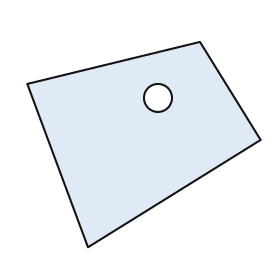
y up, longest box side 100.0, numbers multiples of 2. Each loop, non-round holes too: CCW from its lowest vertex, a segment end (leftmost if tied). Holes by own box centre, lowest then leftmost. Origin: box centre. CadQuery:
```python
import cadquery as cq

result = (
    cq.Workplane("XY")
    .moveTo(-24.0, -44.0)
    .lineTo(50.0, 2.0)
    .lineTo(24.0, 44.0)
    .lineTo(-50.0, 26.0)
    .close()
    .moveTo(6.0, 20.0)
    .circle(6.0)
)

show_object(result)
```